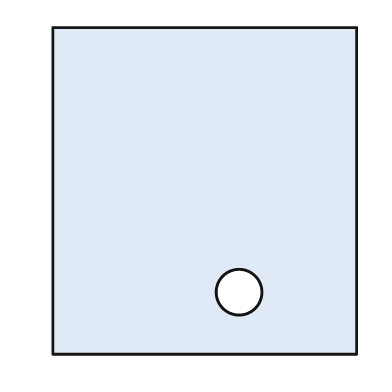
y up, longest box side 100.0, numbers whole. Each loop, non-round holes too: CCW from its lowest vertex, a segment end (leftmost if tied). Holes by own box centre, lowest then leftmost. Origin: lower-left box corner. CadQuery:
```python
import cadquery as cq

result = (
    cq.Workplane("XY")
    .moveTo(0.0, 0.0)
    .lineTo(93.0, 0.0)
    .lineTo(93.0, 100.0)
    .lineTo(0.0, 100.0)
    .close()
    .moveTo(57.0, 19.0)
    .circle(7.0)
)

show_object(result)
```